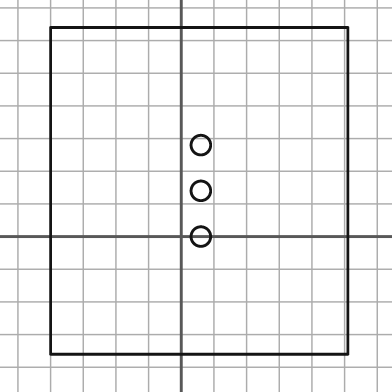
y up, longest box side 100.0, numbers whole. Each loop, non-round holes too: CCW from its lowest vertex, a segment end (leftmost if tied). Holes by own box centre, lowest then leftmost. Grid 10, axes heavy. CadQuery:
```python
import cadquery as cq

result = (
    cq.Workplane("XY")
    .moveTo(-40.0, -36.0)
    .lineTo(51.0, -36.0)
    .lineTo(51.0, 64.0)
    .lineTo(-40.0, 64.0)
    .close()
    .moveTo(6.0, 0.0)
    .circle(3.0)
    .moveTo(6.0, 14.0)
    .circle(3.0)
    .moveTo(6.0, 28.0)
    .circle(3.0)
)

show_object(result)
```